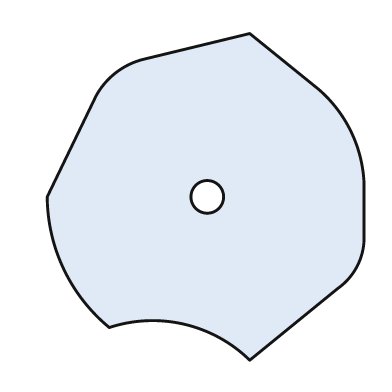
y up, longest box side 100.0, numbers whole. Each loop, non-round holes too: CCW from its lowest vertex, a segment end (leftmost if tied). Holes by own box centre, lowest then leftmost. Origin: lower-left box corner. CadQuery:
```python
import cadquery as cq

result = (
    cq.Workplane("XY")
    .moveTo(62.0, 0.0)
    .lineTo(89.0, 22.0)
    .threePointArc((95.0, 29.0), (97.0, 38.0))
    .lineTo(97.0, 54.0)
    .threePointArc((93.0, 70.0), (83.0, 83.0))
    .lineTo(62.0, 100.0)
    .lineTo(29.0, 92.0)
    .threePointArc((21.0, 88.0), (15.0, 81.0))
    .lineTo(0.0, 50.0)
    .threePointArc((5.0, 28.0), (19.0, 10.0))
    .threePointArc((42.0, 11.0), (62.0, 0.0))
    .close()
    .moveTo(49.0, 50.0)
    .circle(5.0)
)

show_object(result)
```